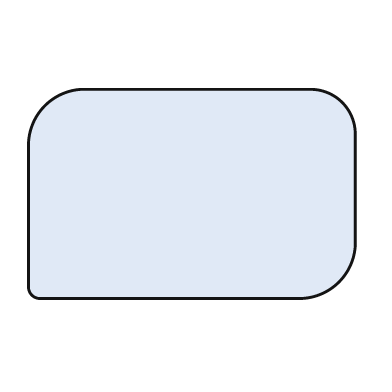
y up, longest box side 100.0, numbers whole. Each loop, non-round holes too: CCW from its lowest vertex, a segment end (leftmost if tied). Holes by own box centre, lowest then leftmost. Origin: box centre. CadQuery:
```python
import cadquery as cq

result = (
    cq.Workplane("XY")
    .moveTo(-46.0, -32.0)
    .lineTo(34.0, -32.0)
    .threePointArc((45.0, -27.0), (50.0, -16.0))
    .lineTo(50.0, 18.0)
    .threePointArc((46.0, 28.0), (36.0, 32.0))
    .lineTo(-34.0, 32.0)
    .threePointArc((-45.0, 27.0), (-50.0, 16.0))
    .lineTo(-50.0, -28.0)
    .threePointArc((-49.0, -31.0), (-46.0, -32.0))
    .close()
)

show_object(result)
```